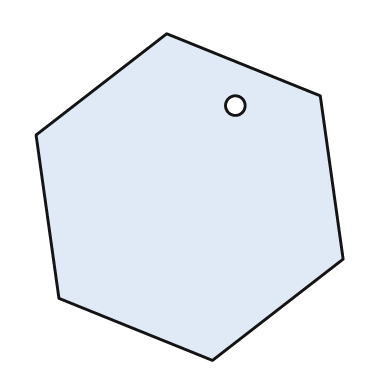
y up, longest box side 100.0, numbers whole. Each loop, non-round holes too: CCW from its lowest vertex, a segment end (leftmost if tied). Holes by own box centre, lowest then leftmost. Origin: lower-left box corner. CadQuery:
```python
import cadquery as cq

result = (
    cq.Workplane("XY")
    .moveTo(54.0, 0.0)
    .lineTo(94.0, 31.0)
    .lineTo(87.0, 81.0)
    .lineTo(40.0, 100.0)
    .lineTo(0.0, 69.0)
    .lineTo(7.0, 19.0)
    .close()
    .moveTo(61.0, 78.0)
    .circle(3.0)
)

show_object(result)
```